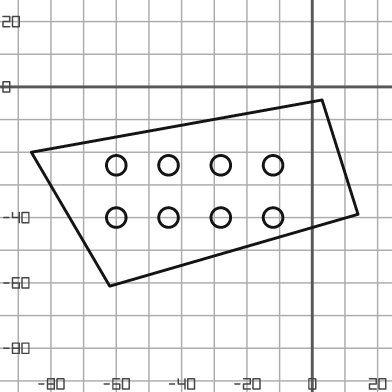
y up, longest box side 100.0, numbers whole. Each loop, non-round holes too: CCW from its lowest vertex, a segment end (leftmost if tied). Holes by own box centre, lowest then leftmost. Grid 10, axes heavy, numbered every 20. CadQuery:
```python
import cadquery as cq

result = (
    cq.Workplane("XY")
    .moveTo(-62.0, -61.0)
    .lineTo(14.0, -39.0)
    .lineTo(3.0, -4.0)
    .lineTo(-86.0, -20.0)
    .close()
    .moveTo(-60.0, -40.0)
    .circle(3.0)
    .moveTo(-44.0, -40.0)
    .circle(3.0)
    .moveTo(-28.0, -40.0)
    .circle(3.0)
    .moveTo(-12.0, -40.0)
    .circle(3.0)
    .moveTo(-60.0, -24.0)
    .circle(3.0)
    .moveTo(-44.0, -24.0)
    .circle(3.0)
    .moveTo(-28.0, -24.0)
    .circle(3.0)
    .moveTo(-12.0, -24.0)
    .circle(3.0)
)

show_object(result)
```